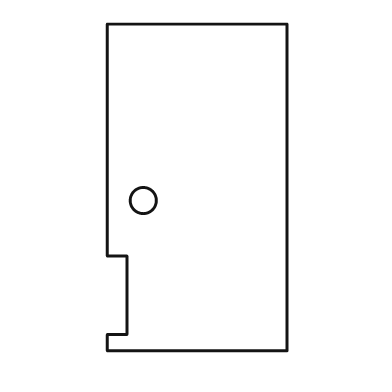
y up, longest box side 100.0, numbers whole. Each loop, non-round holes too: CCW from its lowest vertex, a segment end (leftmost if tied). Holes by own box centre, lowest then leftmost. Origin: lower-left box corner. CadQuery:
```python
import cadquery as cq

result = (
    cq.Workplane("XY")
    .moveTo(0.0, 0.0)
    .lineTo(55.0, 0.0)
    .lineTo(55.0, 100.0)
    .lineTo(0.0, 100.0)
    .lineTo(0.0, 29.0)
    .lineTo(6.0, 29.0)
    .lineTo(6.0, 5.0)
    .lineTo(0.0, 5.0)
    .close()
    .moveTo(11.0, 46.0)
    .circle(4.0)
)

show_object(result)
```